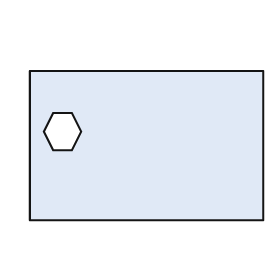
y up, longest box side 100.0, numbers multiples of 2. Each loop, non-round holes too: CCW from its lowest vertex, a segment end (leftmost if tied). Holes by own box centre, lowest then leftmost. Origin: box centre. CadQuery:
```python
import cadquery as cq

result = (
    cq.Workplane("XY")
    .moveTo(-50.0, -32.0)
    .lineTo(50.0, -32.0)
    .lineTo(50.0, 32.0)
    .lineTo(-50.0, 32.0)
    .close()
    .moveTo(-40.0, -2.0)
    .lineTo(-32.0, -2.0)
    .lineTo(-28.0, 6.0)
    .lineTo(-32.0, 14.0)
    .lineTo(-40.0, 14.0)
    .lineTo(-44.0, 6.0)
    .close()
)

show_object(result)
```